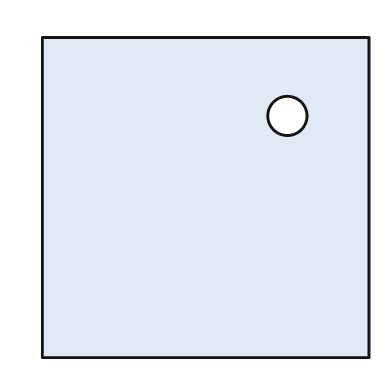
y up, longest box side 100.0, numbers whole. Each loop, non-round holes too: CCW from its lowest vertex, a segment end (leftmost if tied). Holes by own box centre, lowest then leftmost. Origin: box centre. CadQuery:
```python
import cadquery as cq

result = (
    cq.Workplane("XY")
    .moveTo(-50.0, -49.0)
    .lineTo(50.0, -49.0)
    .lineTo(50.0, 49.0)
    .lineTo(-50.0, 49.0)
    .close()
    .moveTo(25.0, 25.0)
    .circle(6.0)
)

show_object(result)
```